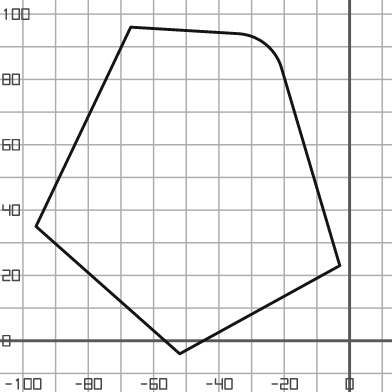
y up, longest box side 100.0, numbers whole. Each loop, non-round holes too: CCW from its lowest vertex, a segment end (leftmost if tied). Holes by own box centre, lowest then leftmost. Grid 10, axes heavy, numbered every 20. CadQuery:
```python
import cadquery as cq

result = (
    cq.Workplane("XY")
    .moveTo(-52.0, -4.0)
    .lineTo(-3.0, 23.0)
    .lineTo(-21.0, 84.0)
    .threePointArc((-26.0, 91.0), (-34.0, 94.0))
    .lineTo(-67.0, 96.0)
    .lineTo(-96.0, 35.0)
    .close()
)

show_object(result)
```